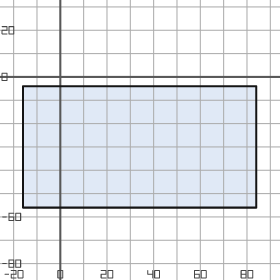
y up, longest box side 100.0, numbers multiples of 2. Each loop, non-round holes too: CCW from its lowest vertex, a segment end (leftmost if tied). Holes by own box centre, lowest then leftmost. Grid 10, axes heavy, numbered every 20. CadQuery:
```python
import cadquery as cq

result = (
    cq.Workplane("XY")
    .moveTo(-16.0, -56.0)
    .lineTo(84.0, -56.0)
    .lineTo(84.0, -4.0)
    .lineTo(-16.0, -4.0)
    .close()
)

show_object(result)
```